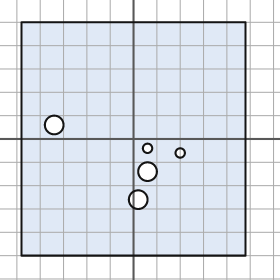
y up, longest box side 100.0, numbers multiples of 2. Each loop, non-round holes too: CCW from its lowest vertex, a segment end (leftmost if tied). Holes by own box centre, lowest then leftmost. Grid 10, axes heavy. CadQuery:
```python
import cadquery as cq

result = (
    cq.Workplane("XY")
    .moveTo(-48.0, -50.0)
    .lineTo(48.0, -50.0)
    .lineTo(48.0, 50.0)
    .lineTo(-48.0, 50.0)
    .close()
    .moveTo(2.0, -26.0)
    .circle(4.0)
    .moveTo(6.0, -14.0)
    .circle(4.0)
    .moveTo(20.0, -6.0)
    .circle(2.0)
    .moveTo(6.0, -4.0)
    .circle(2.0)
    .moveTo(-34.0, 6.0)
    .circle(4.0)
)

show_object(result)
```